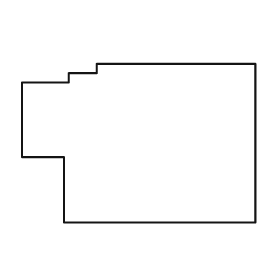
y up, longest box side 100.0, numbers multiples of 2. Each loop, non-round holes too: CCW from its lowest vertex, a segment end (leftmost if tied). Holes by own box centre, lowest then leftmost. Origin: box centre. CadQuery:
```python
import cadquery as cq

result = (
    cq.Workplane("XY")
    .moveTo(-32.0, -34.0)
    .lineTo(50.0, -34.0)
    .lineTo(50.0, 34.0)
    .lineTo(-18.0, 34.0)
    .lineTo(-18.0, 30.0)
    .lineTo(-30.0, 30.0)
    .lineTo(-30.0, 26.0)
    .lineTo(-50.0, 26.0)
    .lineTo(-50.0, -6.0)
    .lineTo(-32.0, -6.0)
    .close()
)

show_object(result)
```